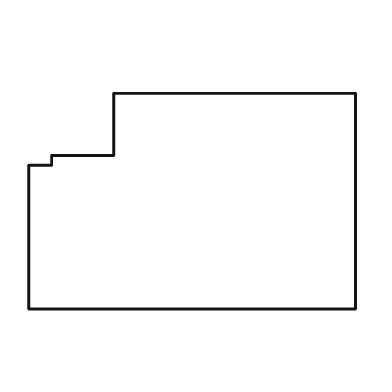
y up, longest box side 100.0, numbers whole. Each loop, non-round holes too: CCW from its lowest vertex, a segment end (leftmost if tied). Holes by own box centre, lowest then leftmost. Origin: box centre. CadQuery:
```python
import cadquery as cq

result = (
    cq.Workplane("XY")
    .moveTo(-50.0, -33.0)
    .lineTo(50.0, -33.0)
    .lineTo(50.0, 33.0)
    .lineTo(-24.0, 33.0)
    .lineTo(-24.0, 14.0)
    .lineTo(-43.0, 14.0)
    .lineTo(-43.0, 11.0)
    .lineTo(-50.0, 11.0)
    .close()
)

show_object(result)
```